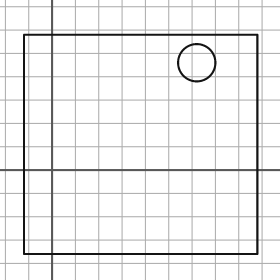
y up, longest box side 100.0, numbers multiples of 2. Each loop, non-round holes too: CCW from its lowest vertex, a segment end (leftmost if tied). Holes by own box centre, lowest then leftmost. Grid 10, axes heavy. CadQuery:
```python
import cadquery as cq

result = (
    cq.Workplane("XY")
    .moveTo(-12.0, -36.0)
    .lineTo(88.0, -36.0)
    .lineTo(88.0, 58.0)
    .lineTo(-12.0, 58.0)
    .close()
    .moveTo(62.0, 46.0)
    .circle(8.0)
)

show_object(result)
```